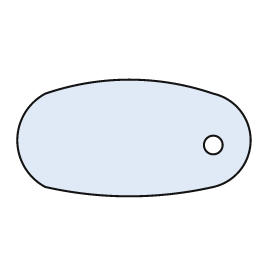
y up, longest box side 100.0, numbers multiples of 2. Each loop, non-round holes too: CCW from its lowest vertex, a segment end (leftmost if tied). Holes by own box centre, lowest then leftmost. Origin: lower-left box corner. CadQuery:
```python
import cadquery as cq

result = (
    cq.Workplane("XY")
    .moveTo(12.0, 4.0)
    .threePointArc((48.0, 0.0), (84.0, 4.0))
    .threePointArc((100.0, 24.0), (84.0, 44.0))
    .threePointArc((48.0, 50.0), (12.0, 44.0))
    .threePointArc((0.0, 24.0), (12.0, 4.0))
    .close()
    .moveTo(84.0, 22.0)
    .circle(4.0)
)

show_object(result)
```